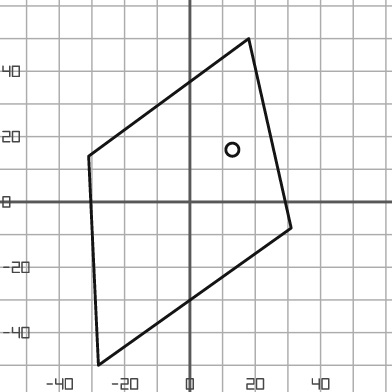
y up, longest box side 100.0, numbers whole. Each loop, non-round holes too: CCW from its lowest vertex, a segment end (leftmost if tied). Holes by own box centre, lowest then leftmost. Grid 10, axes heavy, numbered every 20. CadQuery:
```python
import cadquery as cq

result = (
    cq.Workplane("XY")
    .moveTo(-28.0, -50.0)
    .lineTo(31.0, -8.0)
    .lineTo(18.0, 50.0)
    .lineTo(-31.0, 14.0)
    .close()
    .moveTo(13.0, 16.0)
    .circle(2.0)
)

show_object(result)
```